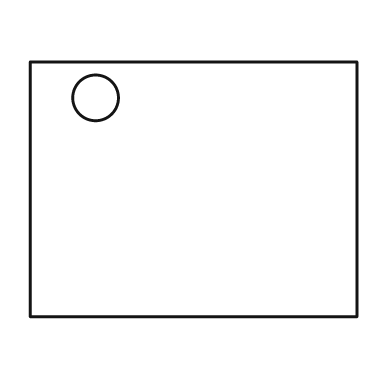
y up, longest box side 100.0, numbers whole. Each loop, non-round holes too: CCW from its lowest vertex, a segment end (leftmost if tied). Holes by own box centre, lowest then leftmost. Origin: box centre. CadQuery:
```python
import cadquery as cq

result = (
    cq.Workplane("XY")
    .moveTo(-50.0, -39.0)
    .lineTo(50.0, -39.0)
    .lineTo(50.0, 39.0)
    .lineTo(-50.0, 39.0)
    .close()
    .moveTo(-30.0, 28.0)
    .circle(7.0)
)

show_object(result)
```